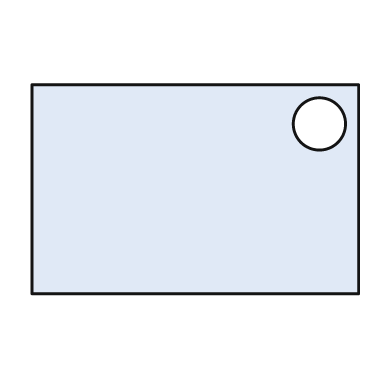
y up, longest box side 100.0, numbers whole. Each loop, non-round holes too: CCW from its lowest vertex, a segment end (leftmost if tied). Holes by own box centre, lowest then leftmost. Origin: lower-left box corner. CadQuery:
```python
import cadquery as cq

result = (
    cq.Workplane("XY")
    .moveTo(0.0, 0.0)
    .lineTo(100.0, 0.0)
    .lineTo(100.0, 64.0)
    .lineTo(0.0, 64.0)
    .close()
    .moveTo(88.0, 52.0)
    .circle(8.0)
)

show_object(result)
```